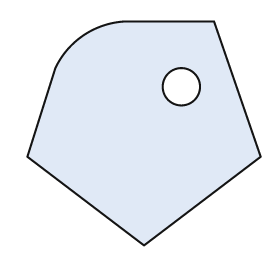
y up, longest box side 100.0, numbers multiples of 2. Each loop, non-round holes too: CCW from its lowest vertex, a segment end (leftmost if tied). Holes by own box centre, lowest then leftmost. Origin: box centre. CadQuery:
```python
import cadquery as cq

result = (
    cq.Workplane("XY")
    .moveTo(0.0, -48.0)
    .lineTo(50.0, -10.0)
    .lineTo(30.0, 48.0)
    .lineTo(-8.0, 48.0)
    .threePointArc((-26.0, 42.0), (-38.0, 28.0))
    .lineTo(-50.0, -10.0)
    .close()
    .moveTo(16.0, 20.0)
    .circle(8.0)
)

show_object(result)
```